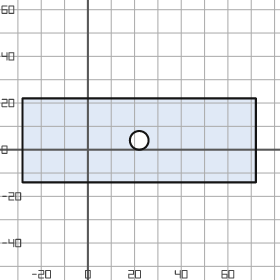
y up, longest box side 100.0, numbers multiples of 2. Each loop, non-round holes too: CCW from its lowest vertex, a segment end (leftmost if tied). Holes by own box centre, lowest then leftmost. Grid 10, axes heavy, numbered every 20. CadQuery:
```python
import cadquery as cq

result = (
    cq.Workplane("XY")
    .moveTo(-28.0, -14.0)
    .lineTo(72.0, -14.0)
    .lineTo(72.0, 22.0)
    .lineTo(-28.0, 22.0)
    .close()
    .moveTo(22.0, 4.0)
    .circle(4.0)
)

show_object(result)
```